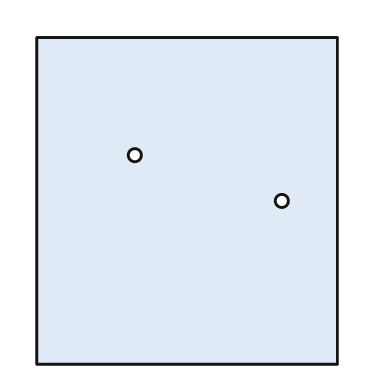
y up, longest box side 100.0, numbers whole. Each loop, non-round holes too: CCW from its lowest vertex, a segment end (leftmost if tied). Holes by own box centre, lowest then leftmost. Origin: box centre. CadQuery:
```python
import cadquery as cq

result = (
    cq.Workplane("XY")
    .moveTo(-46.0, -50.0)
    .lineTo(46.0, -50.0)
    .lineTo(46.0, 50.0)
    .lineTo(-46.0, 50.0)
    .close()
    .moveTo(29.0, 0.0)
    .circle(2.0)
    .moveTo(-16.0, 14.0)
    .circle(2.0)
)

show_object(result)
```